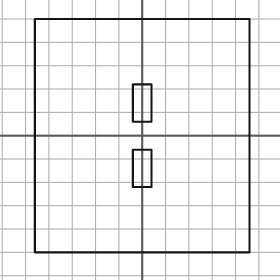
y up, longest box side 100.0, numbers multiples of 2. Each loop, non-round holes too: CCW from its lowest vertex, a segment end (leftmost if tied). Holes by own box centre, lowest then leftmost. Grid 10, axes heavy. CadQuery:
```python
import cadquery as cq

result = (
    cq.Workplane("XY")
    .moveTo(-46.0, -50.0)
    .lineTo(46.0, -50.0)
    .lineTo(46.0, 50.0)
    .lineTo(-46.0, 50.0)
    .close()
    .moveTo(-4.0, -22.0)
    .lineTo(4.0, -22.0)
    .lineTo(4.0, -6.0)
    .lineTo(-4.0, -6.0)
    .close()
    .moveTo(-4.0, 6.0)
    .lineTo(4.0, 6.0)
    .lineTo(4.0, 22.0)
    .lineTo(-4.0, 22.0)
    .close()
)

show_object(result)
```